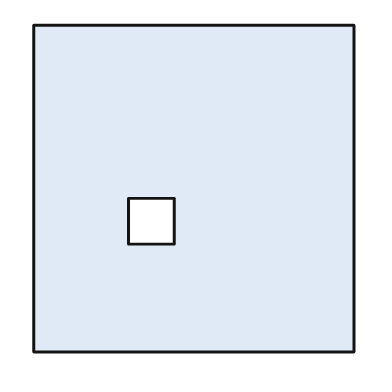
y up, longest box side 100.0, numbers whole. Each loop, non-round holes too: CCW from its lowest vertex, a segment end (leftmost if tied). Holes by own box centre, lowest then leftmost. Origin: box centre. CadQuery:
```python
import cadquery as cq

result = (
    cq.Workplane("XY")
    .moveTo(-49.0, -50.0)
    .lineTo(49.0, -50.0)
    .lineTo(49.0, 50.0)
    .lineTo(-49.0, 50.0)
    .close()
    .moveTo(-20.0, -17.0)
    .lineTo(-6.0, -17.0)
    .lineTo(-6.0, -3.0)
    .lineTo(-20.0, -3.0)
    .close()
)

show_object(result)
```